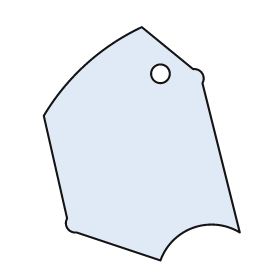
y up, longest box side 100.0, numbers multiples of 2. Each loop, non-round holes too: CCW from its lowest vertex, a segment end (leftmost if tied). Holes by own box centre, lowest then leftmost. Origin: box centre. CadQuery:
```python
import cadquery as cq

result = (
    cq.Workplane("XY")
    .moveTo(8.0, -50.0)
    .threePointArc((22.0, -36.0), (42.0, -38.0))
    .lineTo(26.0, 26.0)
    .threePointArc((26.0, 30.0), (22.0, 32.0))
    .lineTo(0.0, 50.0)
    .threePointArc((-24.0, 34.0), (-42.0, 12.0))
    .lineTo(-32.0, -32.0)
    .threePointArc((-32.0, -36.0), (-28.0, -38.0))
    .close()
    .moveTo(8.0, 30.0)
    .circle(4.0)
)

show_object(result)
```